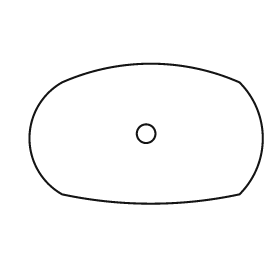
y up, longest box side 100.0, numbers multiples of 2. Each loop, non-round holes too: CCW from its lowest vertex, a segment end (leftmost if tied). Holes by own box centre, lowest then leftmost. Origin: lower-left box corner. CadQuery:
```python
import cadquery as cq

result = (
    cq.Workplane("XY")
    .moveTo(14.0, 4.0)
    .threePointArc((52.0, 0.0), (90.0, 4.0))
    .threePointArc((100.0, 28.0), (90.0, 52.0))
    .threePointArc((52.0, 60.0), (14.0, 52.0))
    .threePointArc((0.0, 28.0), (14.0, 4.0))
    .close()
    .moveTo(50.0, 30.0)
    .circle(4.0)
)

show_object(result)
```